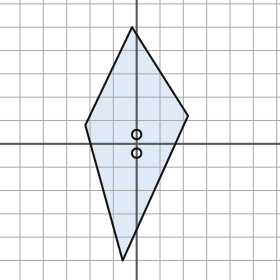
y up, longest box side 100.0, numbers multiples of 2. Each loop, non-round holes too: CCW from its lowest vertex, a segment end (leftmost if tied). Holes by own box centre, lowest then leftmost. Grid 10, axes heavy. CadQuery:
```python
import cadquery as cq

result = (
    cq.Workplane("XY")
    .moveTo(-6.0, -50.0)
    .lineTo(22.0, 12.0)
    .lineTo(-2.0, 50.0)
    .lineTo(-22.0, 8.0)
    .close()
    .moveTo(0.0, -4.0)
    .circle(2.0)
    .moveTo(0.0, 4.0)
    .circle(2.0)
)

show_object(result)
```